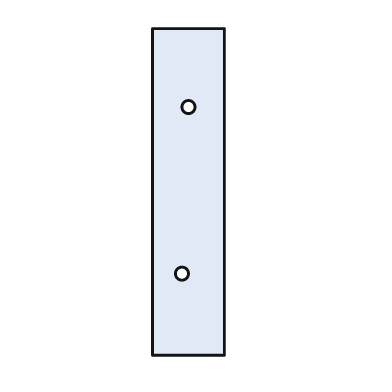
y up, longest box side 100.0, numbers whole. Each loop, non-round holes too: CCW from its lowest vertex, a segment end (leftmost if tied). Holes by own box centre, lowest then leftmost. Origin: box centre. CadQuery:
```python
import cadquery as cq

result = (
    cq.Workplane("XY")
    .moveTo(-11.0, -50.0)
    .lineTo(11.0, -50.0)
    .lineTo(11.0, 50.0)
    .lineTo(-11.0, 50.0)
    .close()
    .moveTo(-2.0, -25.0)
    .circle(2.0)
    .moveTo(0.0, 26.0)
    .circle(2.0)
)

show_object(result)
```